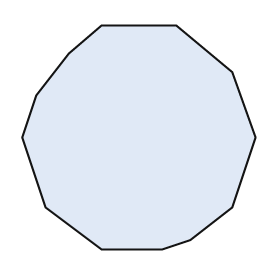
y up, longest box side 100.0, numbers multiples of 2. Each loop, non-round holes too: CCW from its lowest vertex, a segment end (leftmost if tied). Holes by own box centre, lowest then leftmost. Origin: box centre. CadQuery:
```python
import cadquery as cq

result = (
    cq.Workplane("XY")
    .moveTo(-16.0, -48.0)
    .lineTo(10.0, -48.0)
    .lineTo(22.0, -44.0)
    .lineTo(40.0, -30.0)
    .lineTo(50.0, 0.0)
    .lineTo(40.0, 28.0)
    .lineTo(16.0, 48.0)
    .lineTo(-16.0, 48.0)
    .lineTo(-30.0, 36.0)
    .lineTo(-44.0, 18.0)
    .lineTo(-50.0, 0.0)
    .lineTo(-40.0, -30.0)
    .close()
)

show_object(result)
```